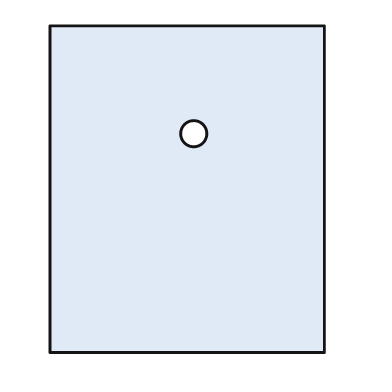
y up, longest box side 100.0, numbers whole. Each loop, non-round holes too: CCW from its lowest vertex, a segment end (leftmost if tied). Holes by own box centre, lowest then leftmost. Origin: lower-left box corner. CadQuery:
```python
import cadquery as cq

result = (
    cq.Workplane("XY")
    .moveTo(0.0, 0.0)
    .lineTo(84.0, 0.0)
    .lineTo(84.0, 100.0)
    .lineTo(0.0, 100.0)
    .close()
    .moveTo(44.0, 67.0)
    .circle(4.0)
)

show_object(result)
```